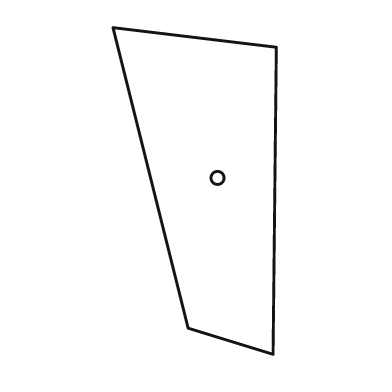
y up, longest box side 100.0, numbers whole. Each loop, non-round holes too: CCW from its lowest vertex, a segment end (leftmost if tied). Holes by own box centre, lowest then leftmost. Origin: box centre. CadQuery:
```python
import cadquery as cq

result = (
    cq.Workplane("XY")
    .moveTo(24.0, -50.0)
    .lineTo(25.0, 44.0)
    .lineTo(-25.0, 50.0)
    .lineTo(-2.0, -42.0)
    .close()
    .moveTo(7.0, 4.0)
    .circle(2.0)
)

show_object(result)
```